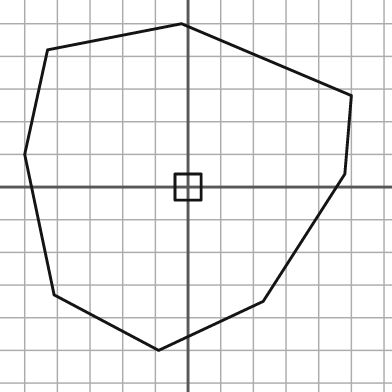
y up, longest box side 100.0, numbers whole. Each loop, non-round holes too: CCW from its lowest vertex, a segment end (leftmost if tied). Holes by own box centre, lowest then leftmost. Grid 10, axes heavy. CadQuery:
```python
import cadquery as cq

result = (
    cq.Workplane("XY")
    .moveTo(-9.0, -50.0)
    .lineTo(23.0, -35.0)
    .lineTo(48.0, 4.0)
    .lineTo(50.0, 28.0)
    .lineTo(-2.0, 50.0)
    .lineTo(-43.0, 42.0)
    .lineTo(-50.0, 10.0)
    .lineTo(-41.0, -33.0)
    .close()
    .moveTo(-4.0, -4.0)
    .lineTo(4.0, -4.0)
    .lineTo(4.0, 4.0)
    .lineTo(-4.0, 4.0)
    .close()
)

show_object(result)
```